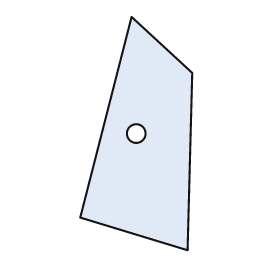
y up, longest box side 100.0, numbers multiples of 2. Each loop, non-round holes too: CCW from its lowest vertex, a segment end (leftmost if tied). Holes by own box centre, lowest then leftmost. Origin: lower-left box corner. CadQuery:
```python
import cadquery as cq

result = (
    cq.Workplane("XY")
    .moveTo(46.0, 0.0)
    .lineTo(48.0, 76.0)
    .lineTo(22.0, 100.0)
    .lineTo(0.0, 14.0)
    .close()
    .moveTo(24.0, 50.0)
    .circle(4.0)
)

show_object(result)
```